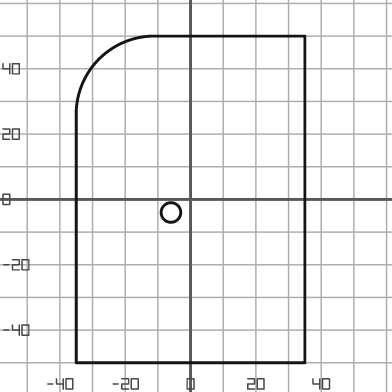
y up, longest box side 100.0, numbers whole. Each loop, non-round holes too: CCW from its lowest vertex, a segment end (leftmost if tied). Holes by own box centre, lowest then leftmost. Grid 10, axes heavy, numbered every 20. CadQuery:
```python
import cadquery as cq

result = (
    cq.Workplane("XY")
    .moveTo(-35.0, -50.0)
    .lineTo(35.0, -50.0)
    .lineTo(35.0, 50.0)
    .lineTo(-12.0, 50.0)
    .threePointArc((-28.0, 43.0), (-35.0, 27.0))
    .close()
    .moveTo(-6.0, -4.0)
    .circle(3.0)
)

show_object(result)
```